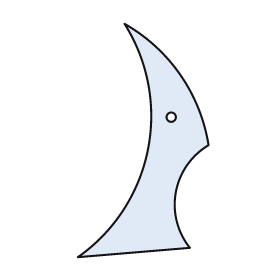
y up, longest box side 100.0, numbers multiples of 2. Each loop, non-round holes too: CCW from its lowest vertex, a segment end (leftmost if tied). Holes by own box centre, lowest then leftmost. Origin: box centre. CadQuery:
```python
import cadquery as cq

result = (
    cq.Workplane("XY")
    .moveTo(-28.0, -50.0)
    .lineTo(20.0, -46.0)
    .threePointArc((14.0, -22.0), (28.0, -2.0))
    .threePointArc((16.0, 28.0), (-8.0, 50.0))
    .threePointArc((2.0, -4.0), (-28.0, -50.0))
    .close()
    .moveTo(12.0, 10.0)
    .circle(2.0)
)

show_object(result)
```